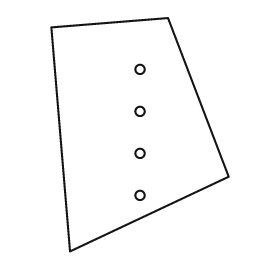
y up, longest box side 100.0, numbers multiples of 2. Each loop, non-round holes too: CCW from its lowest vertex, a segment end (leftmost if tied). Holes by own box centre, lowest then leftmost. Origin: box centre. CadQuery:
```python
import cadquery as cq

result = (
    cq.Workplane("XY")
    .moveTo(-30.0, -50.0)
    .lineTo(38.0, -18.0)
    .lineTo(12.0, 50.0)
    .lineTo(-38.0, 46.0)
    .close()
    .moveTo(0.0, -26.0)
    .circle(2.0)
    .moveTo(0.0, -8.0)
    .circle(2.0)
    .moveTo(0.0, 10.0)
    .circle(2.0)
    .moveTo(0.0, 28.0)
    .circle(2.0)
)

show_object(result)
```